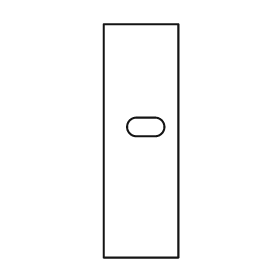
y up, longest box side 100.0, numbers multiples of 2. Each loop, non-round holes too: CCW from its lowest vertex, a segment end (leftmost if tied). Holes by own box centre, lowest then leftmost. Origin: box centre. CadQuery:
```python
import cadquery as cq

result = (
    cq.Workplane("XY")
    .moveTo(-16.0, -50.0)
    .lineTo(16.0, -50.0)
    .lineTo(16.0, 50.0)
    .lineTo(-16.0, 50.0)
    .close()
    .moveTo(-2.0, 2.0)
    .lineTo(6.0, 2.0)
    .threePointArc((10.0, 6.0), (6.0, 10.0))
    .lineTo(-2.0, 10.0)
    .threePointArc((-6.0, 6.0), (-2.0, 2.0))
    .close()
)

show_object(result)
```